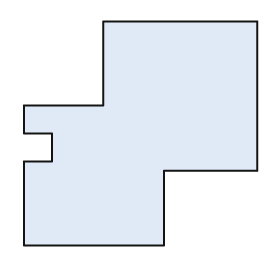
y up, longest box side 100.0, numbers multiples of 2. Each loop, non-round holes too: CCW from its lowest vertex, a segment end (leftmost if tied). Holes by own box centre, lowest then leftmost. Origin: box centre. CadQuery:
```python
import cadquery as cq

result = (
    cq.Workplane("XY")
    .moveTo(-50.0, -48.0)
    .lineTo(10.0, -48.0)
    .lineTo(10.0, -16.0)
    .lineTo(50.0, -16.0)
    .lineTo(50.0, 48.0)
    .lineTo(-16.0, 48.0)
    .lineTo(-16.0, 12.0)
    .lineTo(-50.0, 12.0)
    .lineTo(-50.0, 0.0)
    .lineTo(-38.0, 0.0)
    .lineTo(-38.0, -12.0)
    .lineTo(-50.0, -12.0)
    .close()
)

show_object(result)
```